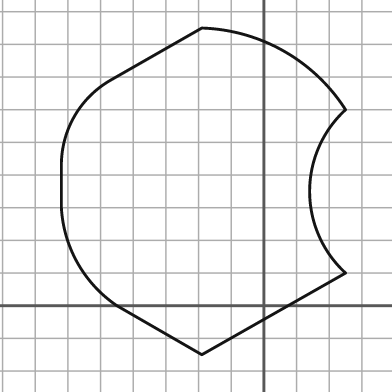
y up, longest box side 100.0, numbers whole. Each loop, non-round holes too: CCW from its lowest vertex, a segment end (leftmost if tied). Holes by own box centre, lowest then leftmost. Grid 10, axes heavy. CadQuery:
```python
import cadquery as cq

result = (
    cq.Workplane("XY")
    .moveTo(-19.0, -15.0)
    .lineTo(25.0, 10.0)
    .threePointArc((14.0, 35.0), (25.0, 60.0))
    .threePointArc((6.0, 78.0), (-19.0, 85.0))
    .lineTo(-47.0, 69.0)
    .threePointArc((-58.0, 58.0), (-62.0, 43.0))
    .lineTo(-62.0, 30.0)
    .threePointArc((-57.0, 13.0), (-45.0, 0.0))
    .close()
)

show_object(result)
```